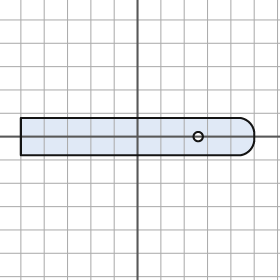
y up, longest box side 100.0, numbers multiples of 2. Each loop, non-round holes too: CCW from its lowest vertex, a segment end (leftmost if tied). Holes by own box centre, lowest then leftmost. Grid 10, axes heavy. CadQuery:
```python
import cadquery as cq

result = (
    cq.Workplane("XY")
    .moveTo(-50.0, -8.0)
    .lineTo(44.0, -8.0)
    .threePointArc((48.0, -6.0), (50.0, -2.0))
    .lineTo(50.0, 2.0)
    .threePointArc((48.0, 6.0), (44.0, 8.0))
    .lineTo(-50.0, 8.0)
    .close()
    .moveTo(26.0, 0.0)
    .circle(2.0)
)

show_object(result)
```